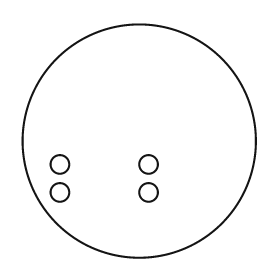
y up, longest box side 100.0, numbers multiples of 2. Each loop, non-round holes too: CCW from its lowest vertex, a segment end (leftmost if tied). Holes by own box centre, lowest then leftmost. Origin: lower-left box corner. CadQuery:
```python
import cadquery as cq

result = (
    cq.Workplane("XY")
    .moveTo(50.0, 50.0)
    .circle(50.0)
    .moveTo(16.0, 28.0)
    .circle(4.0)
    .moveTo(54.0, 28.0)
    .circle(4.0)
    .moveTo(16.0, 40.0)
    .circle(4.0)
    .moveTo(54.0, 40.0)
    .circle(4.0)
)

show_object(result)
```